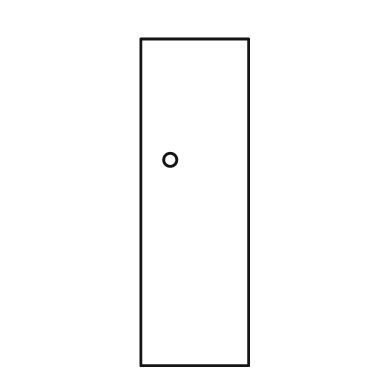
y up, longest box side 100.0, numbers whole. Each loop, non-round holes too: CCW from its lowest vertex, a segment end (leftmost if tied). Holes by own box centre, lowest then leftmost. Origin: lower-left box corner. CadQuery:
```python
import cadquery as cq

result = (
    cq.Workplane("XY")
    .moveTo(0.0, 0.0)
    .lineTo(33.0, 0.0)
    .lineTo(33.0, 100.0)
    .lineTo(0.0, 100.0)
    .close()
    .moveTo(9.0, 63.0)
    .circle(2.0)
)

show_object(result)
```